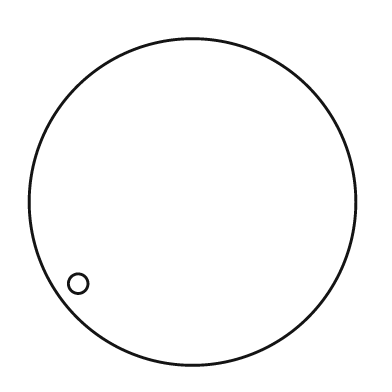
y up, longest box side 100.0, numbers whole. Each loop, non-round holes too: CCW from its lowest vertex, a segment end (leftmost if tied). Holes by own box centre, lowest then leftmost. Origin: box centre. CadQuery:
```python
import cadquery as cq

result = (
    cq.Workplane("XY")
    .moveTo(0.0, 0.0)
    .circle(50.0)
    .moveTo(-35.0, -25.0)
    .circle(3.0)
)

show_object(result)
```